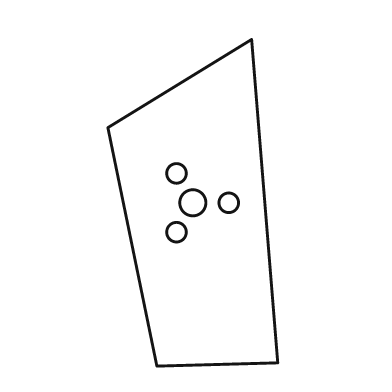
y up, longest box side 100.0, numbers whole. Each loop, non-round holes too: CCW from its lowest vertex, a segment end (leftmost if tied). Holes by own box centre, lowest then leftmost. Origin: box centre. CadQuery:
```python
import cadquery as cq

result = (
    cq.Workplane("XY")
    .moveTo(-11.0, -50.0)
    .lineTo(26.0, -49.0)
    .lineTo(18.0, 50.0)
    .lineTo(-26.0, 23.0)
    .close()
    .moveTo(-5.0, -9.0)
    .circle(3.0)
    .moveTo(0.0, 0.0)
    .circle(4.0)
    .moveTo(11.0, 0.0)
    .circle(3.0)
    .moveTo(-5.0, 9.0)
    .circle(3.0)
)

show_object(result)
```